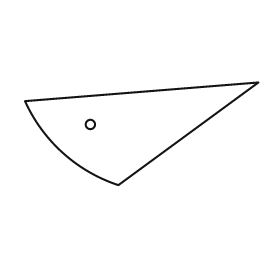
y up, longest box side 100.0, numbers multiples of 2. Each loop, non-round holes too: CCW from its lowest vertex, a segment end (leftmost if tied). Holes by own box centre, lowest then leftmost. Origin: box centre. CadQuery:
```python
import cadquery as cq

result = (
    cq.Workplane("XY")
    .moveTo(-10.0, -22.0)
    .lineTo(50.0, 22.0)
    .lineTo(-50.0, 14.0)
    .threePointArc((-34.0, -8.0), (-10.0, -22.0))
    .close()
    .moveTo(-22.0, 4.0)
    .circle(2.0)
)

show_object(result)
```